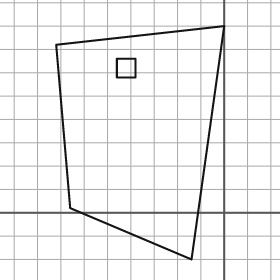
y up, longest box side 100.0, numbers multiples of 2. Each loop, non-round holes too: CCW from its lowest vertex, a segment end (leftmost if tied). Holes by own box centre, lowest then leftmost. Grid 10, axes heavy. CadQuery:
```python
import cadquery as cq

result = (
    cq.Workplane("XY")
    .moveTo(-14.0, -20.0)
    .lineTo(0.0, 80.0)
    .lineTo(-72.0, 72.0)
    .lineTo(-66.0, 2.0)
    .close()
    .moveTo(-46.0, 58.0)
    .lineTo(-38.0, 58.0)
    .lineTo(-38.0, 66.0)
    .lineTo(-46.0, 66.0)
    .close()
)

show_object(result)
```